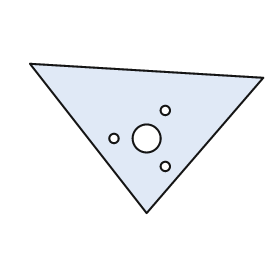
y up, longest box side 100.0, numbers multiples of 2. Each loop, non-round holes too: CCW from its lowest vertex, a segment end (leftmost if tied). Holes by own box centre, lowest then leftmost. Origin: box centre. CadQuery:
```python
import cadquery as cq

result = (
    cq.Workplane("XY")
    .moveTo(0.0, -32.0)
    .lineTo(50.0, 26.0)
    .lineTo(-50.0, 32.0)
    .close()
    .moveTo(8.0, -12.0)
    .circle(2.0)
    .moveTo(-14.0, 0.0)
    .circle(2.0)
    .moveTo(0.0, 0.0)
    .circle(6.0)
    .moveTo(8.0, 12.0)
    .circle(2.0)
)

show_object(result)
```